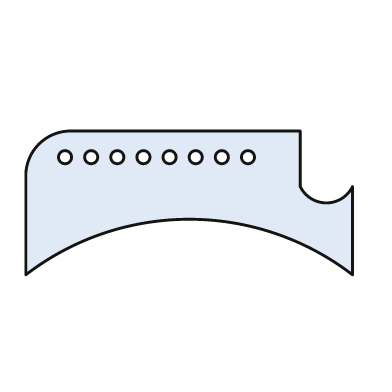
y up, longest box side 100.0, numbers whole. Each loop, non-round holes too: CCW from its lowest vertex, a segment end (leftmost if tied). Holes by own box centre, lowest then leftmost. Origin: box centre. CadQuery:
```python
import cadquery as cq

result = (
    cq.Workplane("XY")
    .moveTo(-50.0, -22.0)
    .threePointArc((0.0, -5.0), (50.0, -22.0))
    .lineTo(50.0, 5.0)
    .threePointArc((42.0, 0.0), (34.0, 5.0))
    .lineTo(34.0, 22.0)
    .lineTo(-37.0, 22.0)
    .threePointArc((-46.0, 18.0), (-50.0, 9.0))
    .close()
    .moveTo(-38.0, 14.0)
    .circle(2.0)
    .moveTo(-30.0, 14.0)
    .circle(2.0)
    .moveTo(-22.0, 14.0)
    .circle(2.0)
    .moveTo(-14.0, 14.0)
    .circle(2.0)
    .moveTo(-6.0, 14.0)
    .circle(2.0)
    .moveTo(2.0, 14.0)
    .circle(2.0)
    .moveTo(10.0, 14.0)
    .circle(2.0)
    .moveTo(18.0, 14.0)
    .circle(2.0)
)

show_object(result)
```